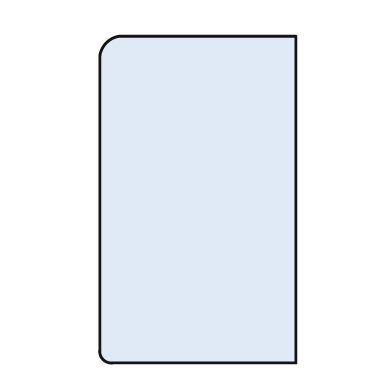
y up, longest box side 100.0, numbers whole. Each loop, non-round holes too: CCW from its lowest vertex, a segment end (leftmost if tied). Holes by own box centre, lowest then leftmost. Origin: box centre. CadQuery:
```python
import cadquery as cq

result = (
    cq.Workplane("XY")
    .moveTo(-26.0, -50.0)
    .lineTo(30.0, -50.0)
    .lineTo(30.0, 50.0)
    .lineTo(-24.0, 50.0)
    .threePointArc((-28.0, 48.0), (-30.0, 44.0))
    .lineTo(-30.0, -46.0)
    .threePointArc((-29.0, -49.0), (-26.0, -50.0))
    .close()
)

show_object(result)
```